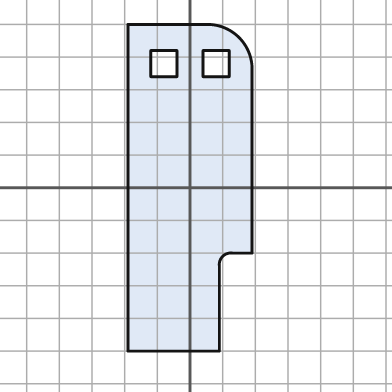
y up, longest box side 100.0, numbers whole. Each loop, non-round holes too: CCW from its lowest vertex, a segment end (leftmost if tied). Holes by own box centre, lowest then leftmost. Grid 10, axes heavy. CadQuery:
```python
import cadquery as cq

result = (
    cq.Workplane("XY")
    .moveTo(-19.0, -50.0)
    .lineTo(9.0, -50.0)
    .lineTo(9.0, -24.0)
    .threePointArc((10.0, -21.0), (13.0, -20.0))
    .lineTo(19.0, -20.0)
    .lineTo(19.0, 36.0)
    .threePointArc((15.0, 46.0), (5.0, 50.0))
    .lineTo(-19.0, 50.0)
    .close()
    .moveTo(-12.0, 34.0)
    .lineTo(-4.0, 34.0)
    .lineTo(-4.0, 42.0)
    .lineTo(-12.0, 42.0)
    .close()
    .moveTo(4.0, 34.0)
    .lineTo(12.0, 34.0)
    .lineTo(12.0, 42.0)
    .lineTo(4.0, 42.0)
    .close()
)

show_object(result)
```